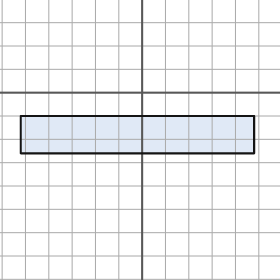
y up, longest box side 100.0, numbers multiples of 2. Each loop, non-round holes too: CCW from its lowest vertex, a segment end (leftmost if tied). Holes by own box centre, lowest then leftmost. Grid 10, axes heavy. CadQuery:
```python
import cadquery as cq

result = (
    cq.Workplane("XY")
    .moveTo(-52.0, -26.0)
    .lineTo(48.0, -26.0)
    .lineTo(48.0, -10.0)
    .lineTo(-52.0, -10.0)
    .close()
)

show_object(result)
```